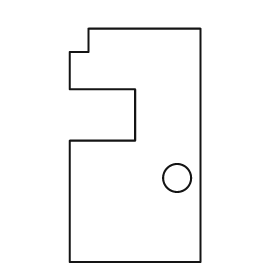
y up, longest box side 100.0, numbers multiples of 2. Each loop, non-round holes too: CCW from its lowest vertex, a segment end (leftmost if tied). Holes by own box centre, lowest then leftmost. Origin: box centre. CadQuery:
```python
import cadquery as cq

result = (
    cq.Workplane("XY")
    .moveTo(-28.0, -50.0)
    .lineTo(28.0, -50.0)
    .lineTo(28.0, 50.0)
    .lineTo(-20.0, 50.0)
    .lineTo(-20.0, 40.0)
    .lineTo(-28.0, 40.0)
    .lineTo(-28.0, 24.0)
    .lineTo(0.0, 24.0)
    .lineTo(0.0, 2.0)
    .lineTo(-28.0, 2.0)
    .close()
    .moveTo(18.0, -14.0)
    .circle(6.0)
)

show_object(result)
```